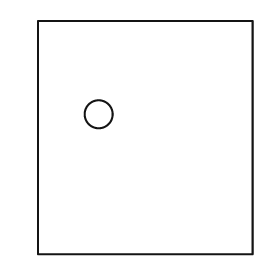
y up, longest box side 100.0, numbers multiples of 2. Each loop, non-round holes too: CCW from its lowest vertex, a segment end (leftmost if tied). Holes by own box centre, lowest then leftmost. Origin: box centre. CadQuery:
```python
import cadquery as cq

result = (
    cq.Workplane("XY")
    .moveTo(-46.0, -50.0)
    .lineTo(46.0, -50.0)
    .lineTo(46.0, 50.0)
    .lineTo(-46.0, 50.0)
    .close()
    .moveTo(-20.0, 10.0)
    .circle(6.0)
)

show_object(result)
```